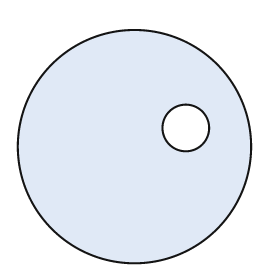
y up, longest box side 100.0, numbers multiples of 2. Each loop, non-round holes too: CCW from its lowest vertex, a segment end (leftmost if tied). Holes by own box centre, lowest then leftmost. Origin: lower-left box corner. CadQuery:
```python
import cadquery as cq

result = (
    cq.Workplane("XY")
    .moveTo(50.0, 50.0)
    .circle(50.0)
    .moveTo(72.0, 58.0)
    .circle(10.0)
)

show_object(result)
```